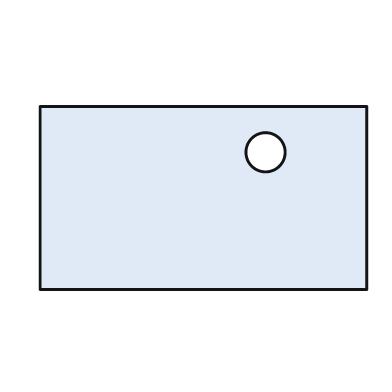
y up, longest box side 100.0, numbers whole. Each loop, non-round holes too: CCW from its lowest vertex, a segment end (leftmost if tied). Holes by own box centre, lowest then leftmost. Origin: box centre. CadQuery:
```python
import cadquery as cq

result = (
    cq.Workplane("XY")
    .moveTo(-50.0, -28.0)
    .lineTo(50.0, -28.0)
    .lineTo(50.0, 28.0)
    .lineTo(-50.0, 28.0)
    .close()
    .moveTo(19.0, 14.0)
    .circle(6.0)
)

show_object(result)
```